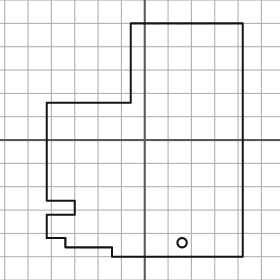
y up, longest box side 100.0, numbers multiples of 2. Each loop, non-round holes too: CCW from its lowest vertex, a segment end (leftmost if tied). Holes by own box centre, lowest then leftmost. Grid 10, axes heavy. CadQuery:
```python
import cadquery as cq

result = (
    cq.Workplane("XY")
    .moveTo(-14.0, -50.0)
    .lineTo(42.0, -50.0)
    .lineTo(42.0, 50.0)
    .lineTo(-6.0, 50.0)
    .lineTo(-6.0, 16.0)
    .lineTo(-42.0, 16.0)
    .lineTo(-42.0, -26.0)
    .lineTo(-30.0, -26.0)
    .lineTo(-30.0, -32.0)
    .lineTo(-42.0, -32.0)
    .lineTo(-42.0, -42.0)
    .lineTo(-34.0, -42.0)
    .lineTo(-34.0, -46.0)
    .lineTo(-14.0, -46.0)
    .close()
    .moveTo(16.0, -44.0)
    .circle(2.0)
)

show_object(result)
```